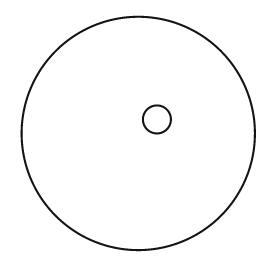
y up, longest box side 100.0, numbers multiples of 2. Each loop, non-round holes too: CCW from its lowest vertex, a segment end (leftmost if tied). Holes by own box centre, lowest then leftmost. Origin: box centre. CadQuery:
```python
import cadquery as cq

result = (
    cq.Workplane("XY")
    .moveTo(0.0, 0.0)
    .circle(50.0)
    .moveTo(8.0, 6.0)
    .circle(6.0)
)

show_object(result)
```